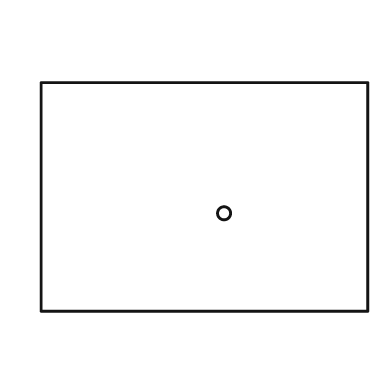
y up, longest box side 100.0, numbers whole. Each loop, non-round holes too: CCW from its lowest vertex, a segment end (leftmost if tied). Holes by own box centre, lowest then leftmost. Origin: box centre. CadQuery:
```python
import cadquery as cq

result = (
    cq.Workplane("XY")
    .moveTo(-50.0, -35.0)
    .lineTo(50.0, -35.0)
    .lineTo(50.0, 35.0)
    .lineTo(-50.0, 35.0)
    .close()
    .moveTo(6.0, -5.0)
    .circle(2.0)
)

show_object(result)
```